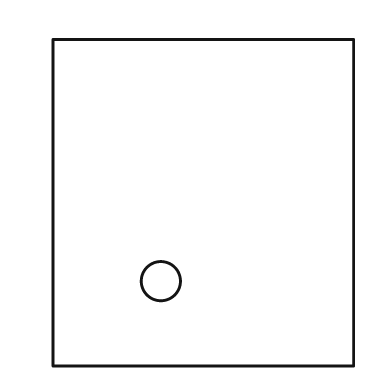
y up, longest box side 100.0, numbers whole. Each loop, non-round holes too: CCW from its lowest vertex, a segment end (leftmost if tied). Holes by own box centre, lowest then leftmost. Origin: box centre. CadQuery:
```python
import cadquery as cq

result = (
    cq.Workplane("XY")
    .moveTo(-46.0, -50.0)
    .lineTo(46.0, -50.0)
    .lineTo(46.0, 50.0)
    .lineTo(-46.0, 50.0)
    .close()
    .moveTo(-13.0, -24.0)
    .circle(6.0)
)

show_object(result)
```